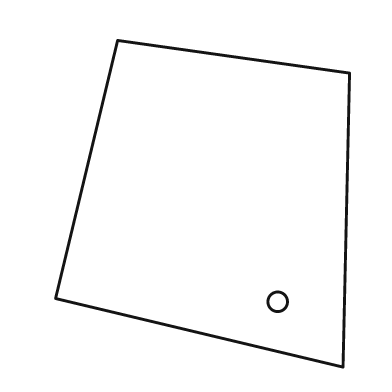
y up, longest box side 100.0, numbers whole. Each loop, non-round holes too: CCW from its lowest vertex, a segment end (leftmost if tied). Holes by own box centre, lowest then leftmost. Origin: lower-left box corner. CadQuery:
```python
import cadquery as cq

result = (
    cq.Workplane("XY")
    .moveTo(88.0, 0.0)
    .lineTo(90.0, 90.0)
    .lineTo(19.0, 100.0)
    .lineTo(0.0, 21.0)
    .close()
    .moveTo(68.0, 20.0)
    .circle(3.0)
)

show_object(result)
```